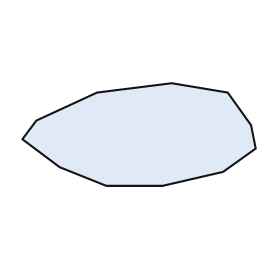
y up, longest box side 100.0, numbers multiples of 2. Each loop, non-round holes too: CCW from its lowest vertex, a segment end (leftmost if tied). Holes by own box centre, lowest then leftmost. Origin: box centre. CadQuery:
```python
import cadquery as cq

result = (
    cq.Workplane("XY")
    .moveTo(-14.0, -22.0)
    .lineTo(10.0, -22.0)
    .lineTo(36.0, -16.0)
    .lineTo(50.0, -6.0)
    .lineTo(48.0, 4.0)
    .lineTo(38.0, 18.0)
    .lineTo(14.0, 22.0)
    .lineTo(-18.0, 18.0)
    .lineTo(-44.0, 6.0)
    .lineTo(-50.0, -2.0)
    .lineTo(-34.0, -14.0)
    .close()
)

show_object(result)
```